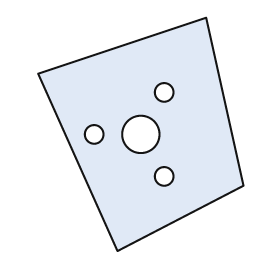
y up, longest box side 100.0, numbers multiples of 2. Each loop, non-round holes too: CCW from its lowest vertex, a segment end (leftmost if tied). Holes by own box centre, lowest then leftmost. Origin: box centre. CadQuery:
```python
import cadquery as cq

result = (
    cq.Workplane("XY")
    .moveTo(-10.0, -50.0)
    .lineTo(44.0, -22.0)
    .lineTo(28.0, 50.0)
    .lineTo(-44.0, 26.0)
    .close()
    .moveTo(10.0, -18.0)
    .circle(4.0)
    .moveTo(-20.0, 0.0)
    .circle(4.0)
    .moveTo(0.0, 0.0)
    .circle(8.0)
    .moveTo(10.0, 18.0)
    .circle(4.0)
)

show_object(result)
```